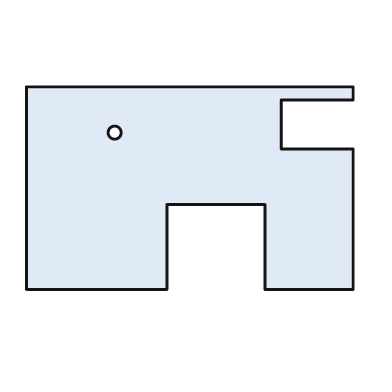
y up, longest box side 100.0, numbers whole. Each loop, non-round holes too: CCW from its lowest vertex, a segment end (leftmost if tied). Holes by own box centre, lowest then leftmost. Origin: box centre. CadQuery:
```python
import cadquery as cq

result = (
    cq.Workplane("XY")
    .moveTo(-50.0, -31.0)
    .lineTo(-7.0, -31.0)
    .lineTo(-7.0, -5.0)
    .lineTo(23.0, -5.0)
    .lineTo(23.0, -31.0)
    .lineTo(50.0, -31.0)
    .lineTo(50.0, 12.0)
    .lineTo(28.0, 12.0)
    .lineTo(28.0, 27.0)
    .lineTo(50.0, 27.0)
    .lineTo(50.0, 31.0)
    .lineTo(-50.0, 31.0)
    .close()
    .moveTo(-23.0, 17.0)
    .circle(2.0)
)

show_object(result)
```